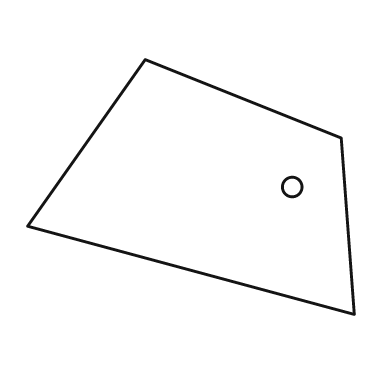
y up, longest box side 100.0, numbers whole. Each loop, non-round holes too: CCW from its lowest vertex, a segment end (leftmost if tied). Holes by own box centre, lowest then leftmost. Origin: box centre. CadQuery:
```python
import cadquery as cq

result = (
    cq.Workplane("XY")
    .moveTo(50.0, -39.0)
    .lineTo(46.0, 15.0)
    .lineTo(-14.0, 39.0)
    .lineTo(-50.0, -12.0)
    .close()
    .moveTo(31.0, 0.0)
    .circle(3.0)
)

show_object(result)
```